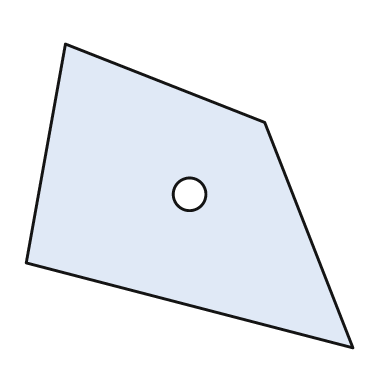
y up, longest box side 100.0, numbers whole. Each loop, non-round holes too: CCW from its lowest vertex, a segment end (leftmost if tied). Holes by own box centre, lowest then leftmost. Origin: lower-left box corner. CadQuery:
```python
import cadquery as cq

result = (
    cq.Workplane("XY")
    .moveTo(100.0, 0.0)
    .lineTo(73.0, 69.0)
    .lineTo(12.0, 93.0)
    .lineTo(0.0, 26.0)
    .close()
    .moveTo(50.0, 47.0)
    .circle(5.0)
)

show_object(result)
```